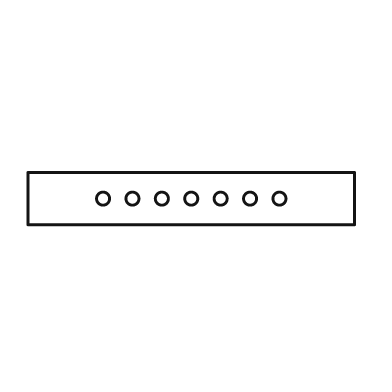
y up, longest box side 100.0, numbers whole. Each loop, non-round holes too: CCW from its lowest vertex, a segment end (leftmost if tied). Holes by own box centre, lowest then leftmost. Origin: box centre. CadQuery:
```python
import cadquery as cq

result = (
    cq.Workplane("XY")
    .moveTo(-50.0, -8.0)
    .lineTo(50.0, -8.0)
    .lineTo(50.0, 8.0)
    .lineTo(-50.0, 8.0)
    .close()
    .moveTo(-27.0, 0.0)
    .circle(2.0)
    .moveTo(-18.0, 0.0)
    .circle(2.0)
    .moveTo(-9.0, 0.0)
    .circle(2.0)
    .moveTo(0.0, 0.0)
    .circle(2.0)
    .moveTo(9.0, 0.0)
    .circle(2.0)
    .moveTo(18.0, 0.0)
    .circle(2.0)
    .moveTo(27.0, 0.0)
    .circle(2.0)
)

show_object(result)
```